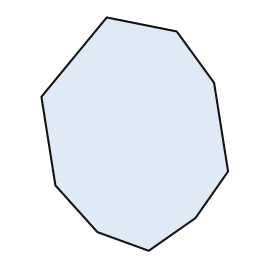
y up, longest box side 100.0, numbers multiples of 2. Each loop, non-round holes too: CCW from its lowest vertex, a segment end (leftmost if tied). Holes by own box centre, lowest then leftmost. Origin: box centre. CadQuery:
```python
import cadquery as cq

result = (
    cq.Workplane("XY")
    .moveTo(6.0, -50.0)
    .lineTo(26.0, -36.0)
    .lineTo(40.0, -16.0)
    .lineTo(34.0, 22.0)
    .lineTo(18.0, 44.0)
    .lineTo(-12.0, 50.0)
    .lineTo(-40.0, 16.0)
    .lineTo(-34.0, -22.0)
    .lineTo(-16.0, -42.0)
    .close()
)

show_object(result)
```